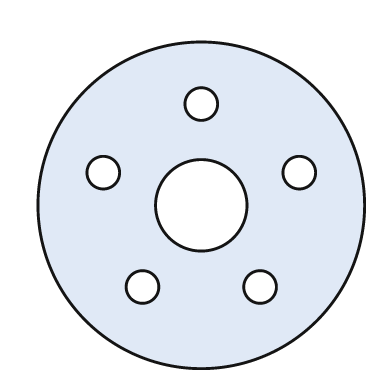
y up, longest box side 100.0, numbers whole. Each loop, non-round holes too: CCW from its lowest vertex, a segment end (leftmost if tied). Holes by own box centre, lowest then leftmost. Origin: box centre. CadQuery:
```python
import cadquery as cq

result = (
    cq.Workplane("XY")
    .moveTo(0.0, 0.0)
    .circle(50.0)
    .moveTo(-18.0, -25.0)
    .circle(5.0)
    .moveTo(18.0, -25.0)
    .circle(5.0)
    .moveTo(0.0, 0.0)
    .circle(14.0)
    .moveTo(-30.0, 10.0)
    .circle(5.0)
    .moveTo(30.0, 10.0)
    .circle(5.0)
    .moveTo(0.0, 31.0)
    .circle(5.0)
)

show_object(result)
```